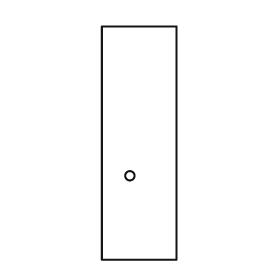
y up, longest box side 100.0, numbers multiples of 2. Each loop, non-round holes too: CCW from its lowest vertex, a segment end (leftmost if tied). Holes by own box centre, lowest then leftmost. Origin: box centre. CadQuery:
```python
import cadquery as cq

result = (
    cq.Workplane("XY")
    .moveTo(-16.0, -50.0)
    .lineTo(16.0, -50.0)
    .lineTo(16.0, 50.0)
    .lineTo(-16.0, 50.0)
    .close()
    .moveTo(-4.0, -14.0)
    .circle(2.0)
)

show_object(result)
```